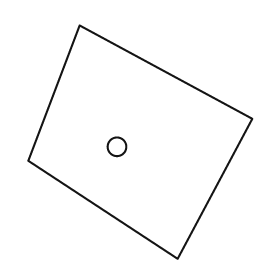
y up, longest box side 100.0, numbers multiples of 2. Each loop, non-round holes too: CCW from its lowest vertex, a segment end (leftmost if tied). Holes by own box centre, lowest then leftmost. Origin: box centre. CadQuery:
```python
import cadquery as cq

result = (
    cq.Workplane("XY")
    .moveTo(16.0, -50.0)
    .lineTo(48.0, 10.0)
    .lineTo(-26.0, 50.0)
    .lineTo(-48.0, -8.0)
    .close()
    .moveTo(-10.0, -2.0)
    .circle(4.0)
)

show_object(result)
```